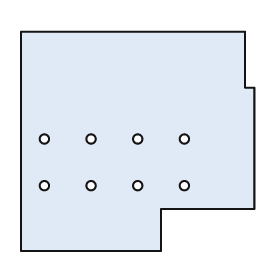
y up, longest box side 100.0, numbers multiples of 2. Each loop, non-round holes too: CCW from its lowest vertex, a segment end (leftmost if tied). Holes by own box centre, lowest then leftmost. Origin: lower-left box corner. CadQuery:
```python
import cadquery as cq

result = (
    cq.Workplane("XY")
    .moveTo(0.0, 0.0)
    .lineTo(60.0, 0.0)
    .lineTo(60.0, 18.0)
    .lineTo(100.0, 18.0)
    .lineTo(100.0, 70.0)
    .lineTo(96.0, 70.0)
    .lineTo(96.0, 94.0)
    .lineTo(0.0, 94.0)
    .close()
    .moveTo(10.0, 28.0)
    .circle(2.0)
    .moveTo(30.0, 28.0)
    .circle(2.0)
    .moveTo(50.0, 28.0)
    .circle(2.0)
    .moveTo(70.0, 28.0)
    .circle(2.0)
    .moveTo(10.0, 48.0)
    .circle(2.0)
    .moveTo(30.0, 48.0)
    .circle(2.0)
    .moveTo(50.0, 48.0)
    .circle(2.0)
    .moveTo(70.0, 48.0)
    .circle(2.0)
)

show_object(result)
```